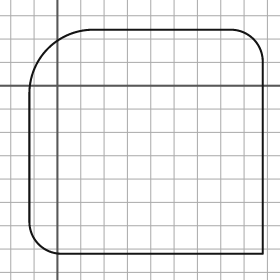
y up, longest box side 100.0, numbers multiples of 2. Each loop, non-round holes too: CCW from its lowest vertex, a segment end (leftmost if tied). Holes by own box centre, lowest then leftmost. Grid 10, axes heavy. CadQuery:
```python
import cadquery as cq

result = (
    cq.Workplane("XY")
    .moveTo(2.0, -72.0)
    .lineTo(88.0, -72.0)
    .lineTo(88.0, 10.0)
    .threePointArc((84.0, 20.0), (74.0, 24.0))
    .lineTo(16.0, 24.0)
    .threePointArc((-4.0, 16.0), (-12.0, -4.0))
    .lineTo(-12.0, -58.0)
    .threePointArc((-8.0, -68.0), (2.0, -72.0))
    .close()
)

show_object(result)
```